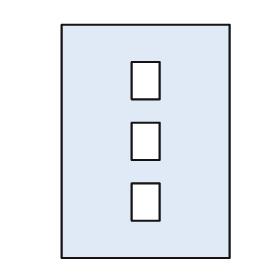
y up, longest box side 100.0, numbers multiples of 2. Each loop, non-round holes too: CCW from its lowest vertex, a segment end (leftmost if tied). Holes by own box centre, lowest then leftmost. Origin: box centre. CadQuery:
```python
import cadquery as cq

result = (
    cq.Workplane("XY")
    .moveTo(-36.0, -50.0)
    .lineTo(36.0, -50.0)
    .lineTo(36.0, 50.0)
    .lineTo(-36.0, 50.0)
    .close()
    .moveTo(-6.0, -34.0)
    .lineTo(6.0, -34.0)
    .lineTo(6.0, -18.0)
    .lineTo(-6.0, -18.0)
    .close()
    .moveTo(-6.0, -8.0)
    .lineTo(6.0, -8.0)
    .lineTo(6.0, 8.0)
    .lineTo(-6.0, 8.0)
    .close()
    .moveTo(-6.0, 18.0)
    .lineTo(6.0, 18.0)
    .lineTo(6.0, 34.0)
    .lineTo(-6.0, 34.0)
    .close()
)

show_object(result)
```